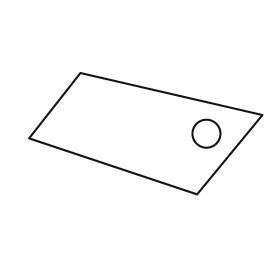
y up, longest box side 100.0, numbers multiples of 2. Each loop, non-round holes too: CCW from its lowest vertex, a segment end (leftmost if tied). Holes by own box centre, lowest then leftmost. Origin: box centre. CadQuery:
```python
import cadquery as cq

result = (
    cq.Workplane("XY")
    .moveTo(22.0, -26.0)
    .lineTo(50.0, 8.0)
    .lineTo(-28.0, 26.0)
    .lineTo(-50.0, -2.0)
    .close()
    .moveTo(26.0, 0.0)
    .circle(6.0)
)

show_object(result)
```